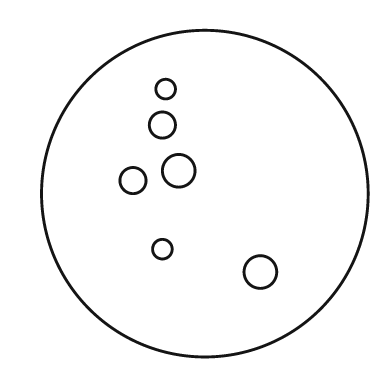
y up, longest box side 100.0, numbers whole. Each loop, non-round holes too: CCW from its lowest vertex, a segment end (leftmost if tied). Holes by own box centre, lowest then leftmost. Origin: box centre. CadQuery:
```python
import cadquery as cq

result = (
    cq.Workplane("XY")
    .moveTo(0.0, 0.0)
    .circle(50.0)
    .moveTo(17.0, -24.0)
    .circle(5.0)
    .moveTo(-13.0, -17.0)
    .circle(3.0)
    .moveTo(-22.0, 4.0)
    .circle(4.0)
    .moveTo(-8.0, 7.0)
    .circle(5.0)
    .moveTo(-13.0, 21.0)
    .circle(4.0)
    .moveTo(-12.0, 32.0)
    .circle(3.0)
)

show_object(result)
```